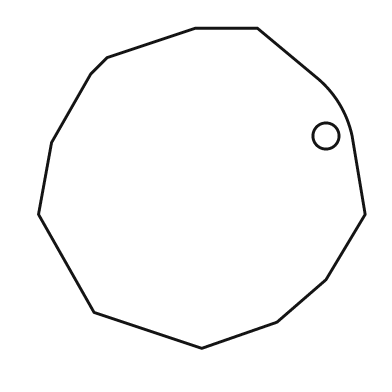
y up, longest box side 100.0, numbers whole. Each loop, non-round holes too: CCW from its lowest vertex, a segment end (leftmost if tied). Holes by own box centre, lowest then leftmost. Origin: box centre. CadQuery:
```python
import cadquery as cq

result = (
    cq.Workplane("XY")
    .moveTo(0.0, -49.0)
    .lineTo(23.0, -41.0)
    .lineTo(38.0, -28.0)
    .lineTo(50.0, -8.0)
    .lineTo(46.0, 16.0)
    .threePointArc((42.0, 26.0), (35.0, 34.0))
    .lineTo(17.0, 49.0)
    .lineTo(-2.0, 49.0)
    .lineTo(-29.0, 40.0)
    .lineTo(-34.0, 35.0)
    .lineTo(-46.0, 14.0)
    .lineTo(-50.0, -8.0)
    .lineTo(-33.0, -38.0)
    .close()
    .moveTo(38.0, 16.0)
    .circle(4.0)
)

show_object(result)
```